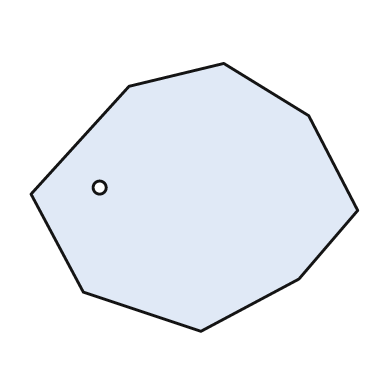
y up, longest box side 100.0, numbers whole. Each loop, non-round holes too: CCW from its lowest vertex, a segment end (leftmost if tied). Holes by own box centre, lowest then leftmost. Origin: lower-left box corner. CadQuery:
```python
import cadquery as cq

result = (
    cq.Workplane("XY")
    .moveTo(52.0, 0.0)
    .lineTo(82.0, 16.0)
    .lineTo(100.0, 37.0)
    .lineTo(85.0, 66.0)
    .lineTo(59.0, 82.0)
    .lineTo(30.0, 75.0)
    .lineTo(0.0, 42.0)
    .lineTo(16.0, 12.0)
    .close()
    .moveTo(21.0, 44.0)
    .circle(2.0)
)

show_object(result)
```